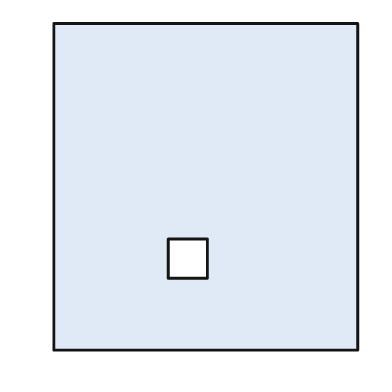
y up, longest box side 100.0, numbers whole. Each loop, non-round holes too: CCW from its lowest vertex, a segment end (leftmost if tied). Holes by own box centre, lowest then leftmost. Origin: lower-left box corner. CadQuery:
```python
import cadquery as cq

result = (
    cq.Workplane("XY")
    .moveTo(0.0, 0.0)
    .lineTo(93.0, 0.0)
    .lineTo(93.0, 100.0)
    .lineTo(0.0, 100.0)
    .close()
    .moveTo(35.0, 22.0)
    .lineTo(47.0, 22.0)
    .lineTo(47.0, 34.0)
    .lineTo(35.0, 34.0)
    .close()
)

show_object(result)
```